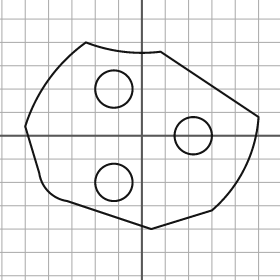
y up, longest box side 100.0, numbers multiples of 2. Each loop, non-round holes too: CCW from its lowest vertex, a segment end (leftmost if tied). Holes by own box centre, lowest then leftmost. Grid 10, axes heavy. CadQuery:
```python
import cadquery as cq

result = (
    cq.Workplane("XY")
    .moveTo(4.0, -40.0)
    .lineTo(30.0, -32.0)
    .threePointArc((44.0, -14.0), (50.0, 8.0))
    .lineTo(8.0, 36.0)
    .threePointArc((-8.0, 36.0), (-24.0, 40.0))
    .threePointArc((-40.0, 24.0), (-50.0, 4.0))
    .lineTo(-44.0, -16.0)
    .threePointArc((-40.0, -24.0), (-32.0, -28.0))
    .close()
    .moveTo(-12.0, -20.0)
    .circle(8.0)
    .moveTo(22.0, 0.0)
    .circle(8.0)
    .moveTo(-12.0, 20.0)
    .circle(8.0)
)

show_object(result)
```